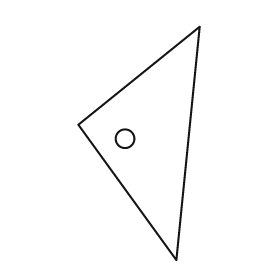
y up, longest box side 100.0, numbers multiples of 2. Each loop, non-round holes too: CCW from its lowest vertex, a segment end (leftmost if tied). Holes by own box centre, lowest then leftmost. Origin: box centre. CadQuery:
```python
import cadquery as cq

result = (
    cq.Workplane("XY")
    .moveTo(16.0, -50.0)
    .lineTo(26.0, 50.0)
    .lineTo(-26.0, 8.0)
    .close()
    .moveTo(-6.0, 2.0)
    .circle(4.0)
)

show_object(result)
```